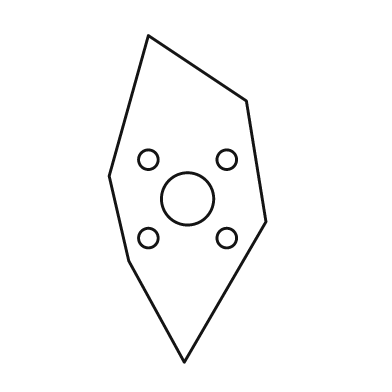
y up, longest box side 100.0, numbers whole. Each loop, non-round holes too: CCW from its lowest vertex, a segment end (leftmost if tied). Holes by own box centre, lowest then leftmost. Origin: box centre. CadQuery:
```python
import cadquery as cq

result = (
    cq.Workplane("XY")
    .moveTo(-1.0, -50.0)
    .lineTo(24.0, -7.0)
    .lineTo(18.0, 30.0)
    .lineTo(-12.0, 50.0)
    .lineTo(-24.0, 7.0)
    .lineTo(-18.0, -19.0)
    .close()
    .moveTo(-12.0, -12.0)
    .circle(3.0)
    .moveTo(12.0, -12.0)
    .circle(3.0)
    .moveTo(0.0, 0.0)
    .circle(8.0)
    .moveTo(-12.0, 12.0)
    .circle(3.0)
    .moveTo(12.0, 12.0)
    .circle(3.0)
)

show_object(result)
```